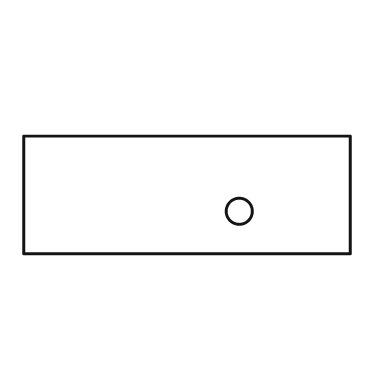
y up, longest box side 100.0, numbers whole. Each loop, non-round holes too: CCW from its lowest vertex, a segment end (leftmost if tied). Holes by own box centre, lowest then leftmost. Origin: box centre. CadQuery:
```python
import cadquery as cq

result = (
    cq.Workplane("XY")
    .moveTo(-50.0, -18.0)
    .lineTo(50.0, -18.0)
    .lineTo(50.0, 18.0)
    .lineTo(-50.0, 18.0)
    .close()
    .moveTo(16.0, -5.0)
    .circle(4.0)
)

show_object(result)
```